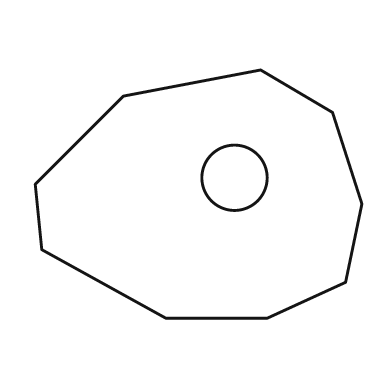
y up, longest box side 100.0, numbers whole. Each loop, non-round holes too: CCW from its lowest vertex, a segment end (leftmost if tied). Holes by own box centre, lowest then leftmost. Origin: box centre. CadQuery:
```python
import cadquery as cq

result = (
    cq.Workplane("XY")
    .moveTo(-10.0, -38.0)
    .lineTo(21.0, -38.0)
    .lineTo(45.0, -27.0)
    .lineTo(50.0, -3.0)
    .lineTo(41.0, 25.0)
    .lineTo(19.0, 38.0)
    .lineTo(-23.0, 30.0)
    .lineTo(-50.0, 3.0)
    .lineTo(-48.0, -17.0)
    .close()
    .moveTo(11.0, 5.0)
    .circle(10.0)
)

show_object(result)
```